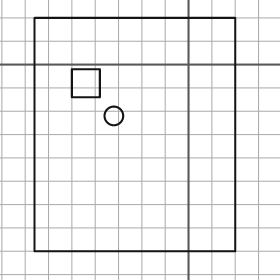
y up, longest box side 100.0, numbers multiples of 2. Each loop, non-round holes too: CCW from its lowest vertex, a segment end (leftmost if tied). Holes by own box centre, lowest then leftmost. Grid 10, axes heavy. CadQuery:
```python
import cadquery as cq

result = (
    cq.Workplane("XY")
    .moveTo(-66.0, -80.0)
    .lineTo(20.0, -80.0)
    .lineTo(20.0, 20.0)
    .lineTo(-66.0, 20.0)
    .close()
    .moveTo(-32.0, -22.0)
    .circle(4.0)
    .moveTo(-50.0, -14.0)
    .lineTo(-38.0, -14.0)
    .lineTo(-38.0, -2.0)
    .lineTo(-50.0, -2.0)
    .close()
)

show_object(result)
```